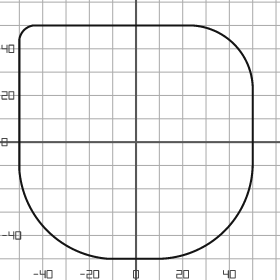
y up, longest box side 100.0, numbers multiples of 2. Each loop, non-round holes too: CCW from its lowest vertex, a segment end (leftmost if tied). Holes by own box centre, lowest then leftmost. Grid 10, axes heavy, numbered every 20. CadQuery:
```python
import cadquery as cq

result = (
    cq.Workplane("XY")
    .moveTo(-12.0, -50.0)
    .lineTo(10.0, -50.0)
    .threePointArc((38.0, -38.0), (50.0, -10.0))
    .lineTo(50.0, 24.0)
    .threePointArc((42.0, 42.0), (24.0, 50.0))
    .lineTo(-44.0, 50.0)
    .threePointArc((-48.0, 48.0), (-50.0, 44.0))
    .lineTo(-50.0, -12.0)
    .threePointArc((-38.0, -38.0), (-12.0, -50.0))
    .close()
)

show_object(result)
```